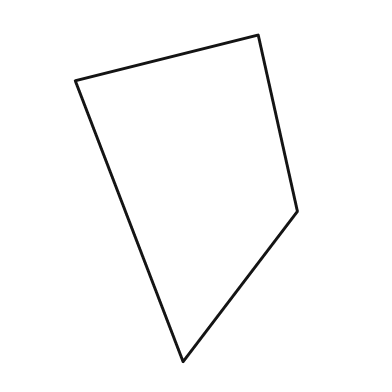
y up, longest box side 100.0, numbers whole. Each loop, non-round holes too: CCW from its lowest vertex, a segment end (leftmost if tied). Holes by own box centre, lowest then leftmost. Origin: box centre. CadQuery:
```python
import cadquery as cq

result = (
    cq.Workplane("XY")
    .moveTo(-1.0, -50.0)
    .lineTo(34.0, -4.0)
    .lineTo(22.0, 50.0)
    .lineTo(-34.0, 36.0)
    .close()
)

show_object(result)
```